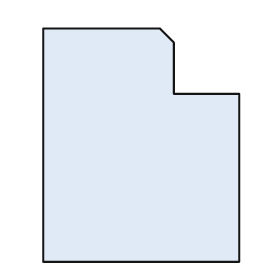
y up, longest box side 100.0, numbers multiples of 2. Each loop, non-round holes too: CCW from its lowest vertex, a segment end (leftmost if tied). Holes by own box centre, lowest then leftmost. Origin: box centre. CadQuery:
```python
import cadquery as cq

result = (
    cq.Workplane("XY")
    .moveTo(-42.0, -50.0)
    .lineTo(42.0, -50.0)
    .lineTo(42.0, 22.0)
    .lineTo(14.0, 22.0)
    .lineTo(14.0, 44.0)
    .lineTo(8.0, 50.0)
    .lineTo(-42.0, 50.0)
    .close()
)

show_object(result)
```